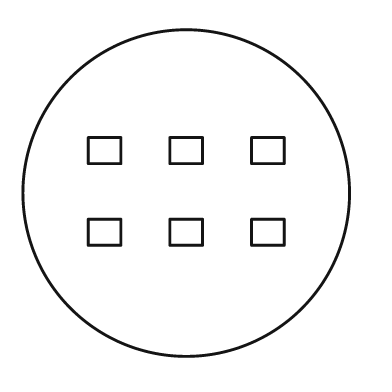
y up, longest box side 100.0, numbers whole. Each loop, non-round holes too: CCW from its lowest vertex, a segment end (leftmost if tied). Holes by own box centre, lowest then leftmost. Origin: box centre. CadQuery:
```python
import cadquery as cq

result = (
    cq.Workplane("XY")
    .moveTo(0.0, 0.0)
    .circle(50.0)
    .moveTo(-30.0, -16.0)
    .lineTo(-20.0, -16.0)
    .lineTo(-20.0, -8.0)
    .lineTo(-30.0, -8.0)
    .close()
    .moveTo(-5.0, -16.0)
    .lineTo(5.0, -16.0)
    .lineTo(5.0, -8.0)
    .lineTo(-5.0, -8.0)
    .close()
    .moveTo(20.0, -16.0)
    .lineTo(30.0, -16.0)
    .lineTo(30.0, -8.0)
    .lineTo(20.0, -8.0)
    .close()
    .moveTo(-30.0, 9.0)
    .lineTo(-20.0, 9.0)
    .lineTo(-20.0, 17.0)
    .lineTo(-30.0, 17.0)
    .close()
    .moveTo(-5.0, 9.0)
    .lineTo(5.0, 9.0)
    .lineTo(5.0, 17.0)
    .lineTo(-5.0, 17.0)
    .close()
    .moveTo(20.0, 9.0)
    .lineTo(30.0, 9.0)
    .lineTo(30.0, 17.0)
    .lineTo(20.0, 17.0)
    .close()
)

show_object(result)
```